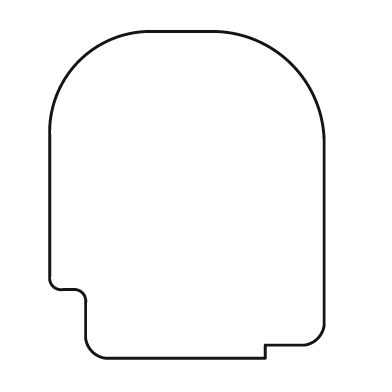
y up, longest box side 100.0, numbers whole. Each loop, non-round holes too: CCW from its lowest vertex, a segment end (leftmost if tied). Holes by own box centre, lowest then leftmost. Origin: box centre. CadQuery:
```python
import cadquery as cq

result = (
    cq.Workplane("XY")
    .moveTo(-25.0, -50.0)
    .lineTo(24.0, -50.0)
    .lineTo(24.0, -46.0)
    .lineTo(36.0, -46.0)
    .threePointArc((40.0, -44.0), (42.0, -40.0))
    .lineTo(42.0, 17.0)
    .threePointArc((32.0, 40.0), (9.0, 50.0))
    .lineTo(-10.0, 50.0)
    .threePointArc((-33.0, 41.0), (-42.0, 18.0))
    .lineTo(-42.0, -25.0)
    .threePointArc((-41.0, -28.0), (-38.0, -29.0))
    .lineTo(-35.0, -29.0)
    .threePointArc((-32.0, -30.0), (-31.0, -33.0))
    .lineTo(-31.0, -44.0)
    .threePointArc((-29.0, -48.0), (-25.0, -50.0))
    .close()
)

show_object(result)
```